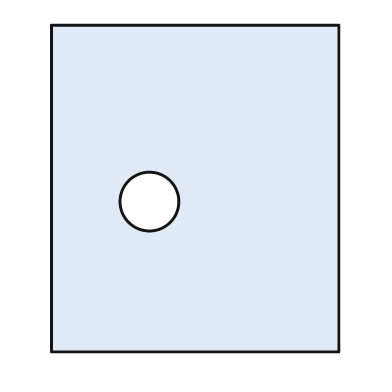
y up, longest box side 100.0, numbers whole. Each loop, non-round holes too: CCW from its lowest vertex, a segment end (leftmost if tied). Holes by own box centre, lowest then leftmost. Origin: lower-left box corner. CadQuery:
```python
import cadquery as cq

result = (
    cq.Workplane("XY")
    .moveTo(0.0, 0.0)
    .lineTo(88.0, 0.0)
    .lineTo(88.0, 100.0)
    .lineTo(0.0, 100.0)
    .close()
    .moveTo(30.0, 46.0)
    .circle(9.0)
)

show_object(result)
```